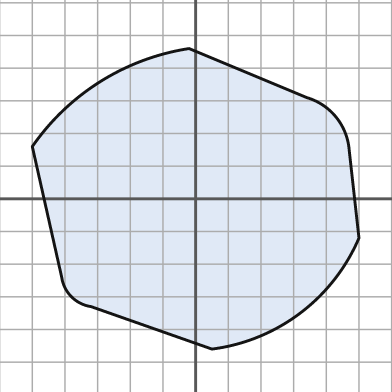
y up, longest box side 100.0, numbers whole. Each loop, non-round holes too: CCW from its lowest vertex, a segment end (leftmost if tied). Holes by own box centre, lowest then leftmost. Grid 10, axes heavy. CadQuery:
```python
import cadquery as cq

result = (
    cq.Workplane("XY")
    .moveTo(5.0, -46.0)
    .threePointArc((32.0, -35.0), (50.0, -12.0))
    .lineTo(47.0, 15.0)
    .threePointArc((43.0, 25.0), (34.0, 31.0))
    .lineTo(-2.0, 46.0)
    .threePointArc((-29.0, 36.0), (-50.0, 16.0))
    .lineTo(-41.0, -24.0)
    .threePointArc((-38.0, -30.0), (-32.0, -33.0))
    .close()
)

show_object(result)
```